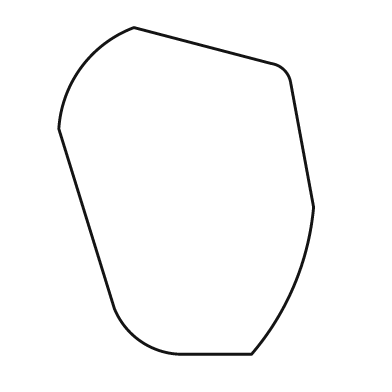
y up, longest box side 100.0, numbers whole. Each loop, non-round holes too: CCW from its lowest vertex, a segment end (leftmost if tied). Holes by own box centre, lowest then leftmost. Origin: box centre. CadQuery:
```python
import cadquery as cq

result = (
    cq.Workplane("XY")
    .moveTo(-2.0, -50.0)
    .lineTo(20.0, -50.0)
    .threePointArc((33.0, -29.0), (39.0, -5.0))
    .lineTo(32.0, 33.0)
    .threePointArc((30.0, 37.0), (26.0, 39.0))
    .lineTo(-16.0, 50.0)
    .threePointArc((-32.0, 38.0), (-39.0, 19.0))
    .lineTo(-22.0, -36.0)
    .threePointArc((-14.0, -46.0), (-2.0, -50.0))
    .close()
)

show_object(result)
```